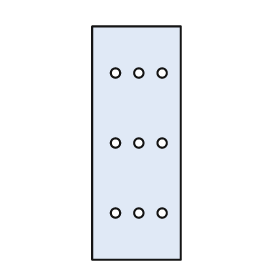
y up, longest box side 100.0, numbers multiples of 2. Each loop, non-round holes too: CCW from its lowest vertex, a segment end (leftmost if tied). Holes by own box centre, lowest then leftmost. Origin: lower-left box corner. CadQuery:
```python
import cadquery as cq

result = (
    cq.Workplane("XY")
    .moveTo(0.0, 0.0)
    .lineTo(38.0, 0.0)
    .lineTo(38.0, 100.0)
    .lineTo(0.0, 100.0)
    .close()
    .moveTo(10.0, 20.0)
    .circle(2.0)
    .moveTo(20.0, 20.0)
    .circle(2.0)
    .moveTo(30.0, 20.0)
    .circle(2.0)
    .moveTo(10.0, 50.0)
    .circle(2.0)
    .moveTo(20.0, 50.0)
    .circle(2.0)
    .moveTo(30.0, 50.0)
    .circle(2.0)
    .moveTo(10.0, 80.0)
    .circle(2.0)
    .moveTo(20.0, 80.0)
    .circle(2.0)
    .moveTo(30.0, 80.0)
    .circle(2.0)
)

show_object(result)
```